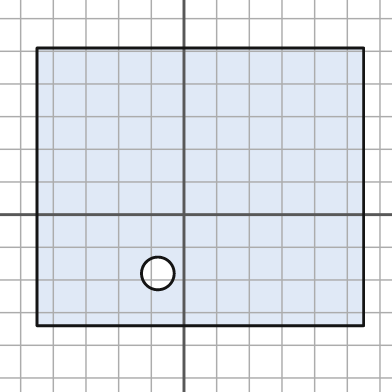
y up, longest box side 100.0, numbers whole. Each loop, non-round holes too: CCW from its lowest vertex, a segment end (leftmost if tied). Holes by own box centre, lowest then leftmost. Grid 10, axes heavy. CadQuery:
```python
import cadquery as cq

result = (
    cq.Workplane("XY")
    .moveTo(-45.0, -34.0)
    .lineTo(55.0, -34.0)
    .lineTo(55.0, 51.0)
    .lineTo(-45.0, 51.0)
    .close()
    .moveTo(-8.0, -18.0)
    .circle(5.0)
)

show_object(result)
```